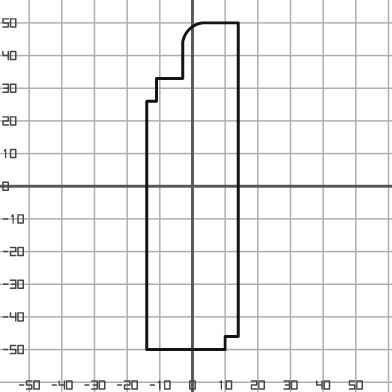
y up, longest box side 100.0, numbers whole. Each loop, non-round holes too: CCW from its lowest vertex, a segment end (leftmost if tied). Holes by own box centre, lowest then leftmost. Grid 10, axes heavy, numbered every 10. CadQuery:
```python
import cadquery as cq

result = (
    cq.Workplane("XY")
    .moveTo(-14.0, -50.0)
    .lineTo(10.0, -50.0)
    .lineTo(10.0, -46.0)
    .lineTo(14.0, -46.0)
    .lineTo(14.0, 50.0)
    .lineTo(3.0, 50.0)
    .threePointArc((-1.0, 48.0), (-3.0, 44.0))
    .lineTo(-3.0, 33.0)
    .lineTo(-11.0, 33.0)
    .lineTo(-11.0, 26.0)
    .lineTo(-14.0, 26.0)
    .close()
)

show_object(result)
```